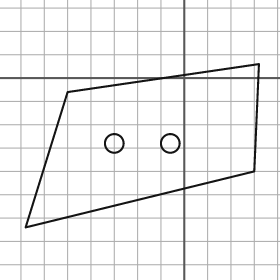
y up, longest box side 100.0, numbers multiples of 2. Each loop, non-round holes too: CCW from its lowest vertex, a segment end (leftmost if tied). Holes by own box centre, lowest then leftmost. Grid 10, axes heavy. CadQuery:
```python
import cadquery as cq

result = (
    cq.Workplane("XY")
    .moveTo(-68.0, -64.0)
    .lineTo(30.0, -40.0)
    .lineTo(32.0, 6.0)
    .lineTo(-50.0, -6.0)
    .close()
    .moveTo(-30.0, -28.0)
    .circle(4.0)
    .moveTo(-6.0, -28.0)
    .circle(4.0)
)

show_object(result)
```